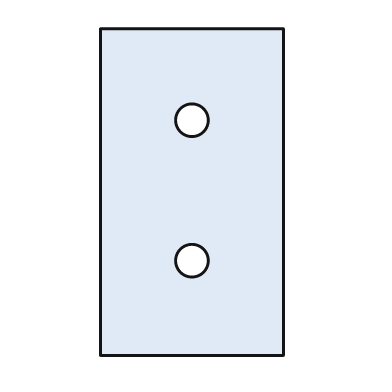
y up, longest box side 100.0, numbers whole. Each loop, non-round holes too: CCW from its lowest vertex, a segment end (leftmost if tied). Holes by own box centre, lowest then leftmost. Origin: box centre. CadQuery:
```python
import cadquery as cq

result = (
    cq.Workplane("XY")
    .moveTo(-28.0, -50.0)
    .lineTo(28.0, -50.0)
    .lineTo(28.0, 50.0)
    .lineTo(-28.0, 50.0)
    .close()
    .moveTo(0.0, -21.0)
    .circle(5.0)
    .moveTo(0.0, 22.0)
    .circle(5.0)
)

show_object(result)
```